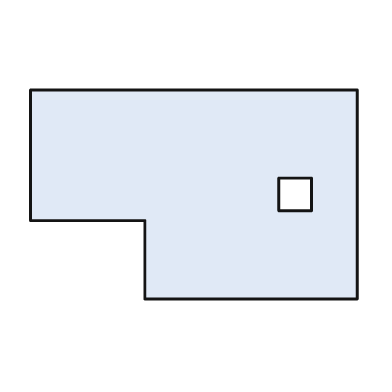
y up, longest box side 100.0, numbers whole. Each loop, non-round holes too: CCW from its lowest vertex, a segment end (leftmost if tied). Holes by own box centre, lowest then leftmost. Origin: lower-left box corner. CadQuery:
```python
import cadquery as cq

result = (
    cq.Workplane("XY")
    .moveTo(35.0, 0.0)
    .lineTo(100.0, 0.0)
    .lineTo(100.0, 64.0)
    .lineTo(0.0, 64.0)
    .lineTo(0.0, 24.0)
    .lineTo(35.0, 24.0)
    .close()
    .moveTo(76.0, 27.0)
    .lineTo(86.0, 27.0)
    .lineTo(86.0, 37.0)
    .lineTo(76.0, 37.0)
    .close()
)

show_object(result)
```